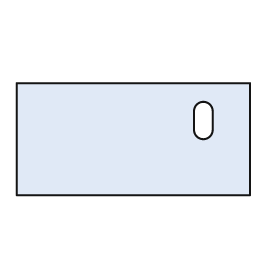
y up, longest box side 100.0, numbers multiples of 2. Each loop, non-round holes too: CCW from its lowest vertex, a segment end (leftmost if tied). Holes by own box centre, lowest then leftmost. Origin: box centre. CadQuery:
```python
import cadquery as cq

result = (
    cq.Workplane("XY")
    .moveTo(-50.0, -24.0)
    .lineTo(50.0, -24.0)
    .lineTo(50.0, 24.0)
    .lineTo(-50.0, 24.0)
    .close()
    .moveTo(26.0, 4.0)
    .threePointArc((30.0, 0.0), (34.0, 4.0))
    .lineTo(34.0, 12.0)
    .threePointArc((30.0, 16.0), (26.0, 12.0))
    .close()
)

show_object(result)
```